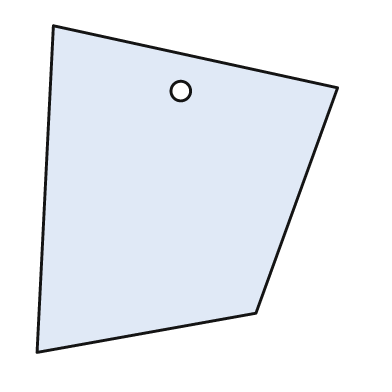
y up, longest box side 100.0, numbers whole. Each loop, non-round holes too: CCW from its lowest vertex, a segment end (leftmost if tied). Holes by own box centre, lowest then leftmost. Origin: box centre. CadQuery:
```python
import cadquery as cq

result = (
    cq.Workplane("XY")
    .moveTo(-46.0, -50.0)
    .lineTo(21.0, -38.0)
    .lineTo(46.0, 31.0)
    .lineTo(-41.0, 50.0)
    .close()
    .moveTo(-2.0, 30.0)
    .circle(3.0)
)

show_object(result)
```